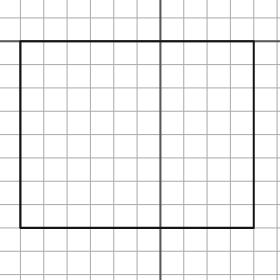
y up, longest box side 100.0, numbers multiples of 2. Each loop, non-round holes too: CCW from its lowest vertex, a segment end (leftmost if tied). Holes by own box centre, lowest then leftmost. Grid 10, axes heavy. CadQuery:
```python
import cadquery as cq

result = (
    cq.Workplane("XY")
    .moveTo(-60.0, -80.0)
    .lineTo(40.0, -80.0)
    .lineTo(40.0, 0.0)
    .lineTo(-60.0, 0.0)
    .close()
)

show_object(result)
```